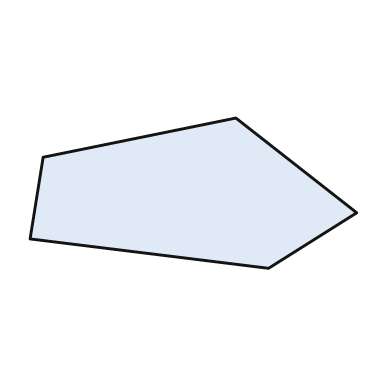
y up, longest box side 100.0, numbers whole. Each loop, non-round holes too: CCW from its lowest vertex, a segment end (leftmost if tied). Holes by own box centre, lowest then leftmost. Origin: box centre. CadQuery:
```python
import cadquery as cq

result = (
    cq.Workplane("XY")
    .moveTo(23.0, -23.0)
    .lineTo(50.0, -6.0)
    .lineTo(13.0, 23.0)
    .lineTo(-46.0, 11.0)
    .lineTo(-50.0, -14.0)
    .close()
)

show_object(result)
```